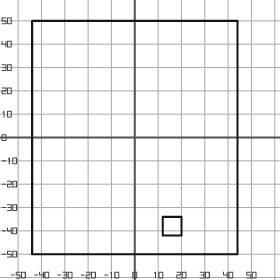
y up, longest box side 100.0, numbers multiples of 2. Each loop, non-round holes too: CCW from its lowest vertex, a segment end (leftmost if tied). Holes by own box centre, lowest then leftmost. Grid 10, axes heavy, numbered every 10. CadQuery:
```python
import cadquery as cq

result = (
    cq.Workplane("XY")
    .moveTo(-44.0, -50.0)
    .lineTo(44.0, -50.0)
    .lineTo(44.0, 50.0)
    .lineTo(-44.0, 50.0)
    .close()
    .moveTo(12.0, -42.0)
    .lineTo(20.0, -42.0)
    .lineTo(20.0, -34.0)
    .lineTo(12.0, -34.0)
    .close()
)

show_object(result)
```